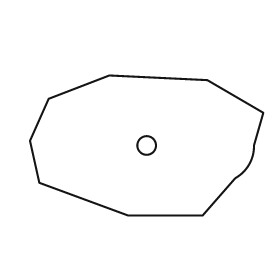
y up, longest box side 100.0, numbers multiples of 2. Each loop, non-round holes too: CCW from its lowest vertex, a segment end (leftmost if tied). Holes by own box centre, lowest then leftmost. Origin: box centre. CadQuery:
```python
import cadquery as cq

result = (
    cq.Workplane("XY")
    .moveTo(-8.0, -30.0)
    .lineTo(24.0, -30.0)
    .lineTo(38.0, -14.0)
    .threePointArc((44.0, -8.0), (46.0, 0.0))
    .lineTo(50.0, 14.0)
    .lineTo(26.0, 28.0)
    .lineTo(-16.0, 30.0)
    .lineTo(-42.0, 20.0)
    .lineTo(-50.0, 2.0)
    .lineTo(-46.0, -16.0)
    .close()
    .moveTo(0.0, 0.0)
    .circle(4.0)
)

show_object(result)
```